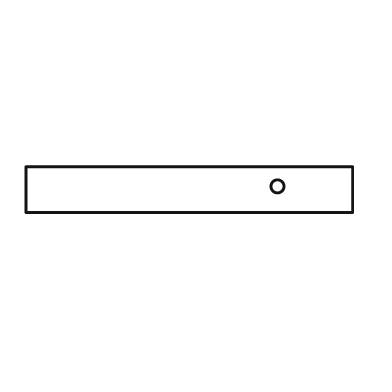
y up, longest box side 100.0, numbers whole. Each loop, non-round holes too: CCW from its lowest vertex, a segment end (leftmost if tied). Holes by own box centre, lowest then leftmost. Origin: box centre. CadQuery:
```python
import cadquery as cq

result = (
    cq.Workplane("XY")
    .moveTo(-50.0, -7.0)
    .lineTo(50.0, -7.0)
    .lineTo(50.0, 7.0)
    .lineTo(-50.0, 7.0)
    .close()
    .moveTo(27.0, 1.0)
    .circle(2.0)
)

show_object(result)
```